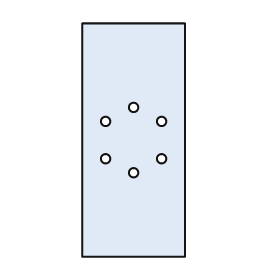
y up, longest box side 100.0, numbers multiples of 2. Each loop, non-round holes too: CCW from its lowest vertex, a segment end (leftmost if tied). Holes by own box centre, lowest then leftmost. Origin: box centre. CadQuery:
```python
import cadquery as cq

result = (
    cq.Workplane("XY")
    .moveTo(-22.0, -50.0)
    .lineTo(22.0, -50.0)
    .lineTo(22.0, 50.0)
    .lineTo(-22.0, 50.0)
    .close()
    .moveTo(0.0, -14.0)
    .circle(2.0)
    .moveTo(-12.0, -8.0)
    .circle(2.0)
    .moveTo(12.0, -8.0)
    .circle(2.0)
    .moveTo(-12.0, 8.0)
    .circle(2.0)
    .moveTo(12.0, 8.0)
    .circle(2.0)
    .moveTo(0.0, 14.0)
    .circle(2.0)
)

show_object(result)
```